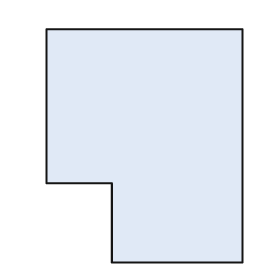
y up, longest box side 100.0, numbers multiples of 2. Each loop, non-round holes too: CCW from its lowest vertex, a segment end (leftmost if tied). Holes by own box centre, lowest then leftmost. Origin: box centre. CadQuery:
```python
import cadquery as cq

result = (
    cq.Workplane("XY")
    .moveTo(-14.0, -50.0)
    .lineTo(42.0, -50.0)
    .lineTo(42.0, 50.0)
    .lineTo(-42.0, 50.0)
    .lineTo(-42.0, -16.0)
    .lineTo(-14.0, -16.0)
    .close()
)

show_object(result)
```